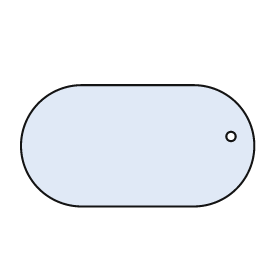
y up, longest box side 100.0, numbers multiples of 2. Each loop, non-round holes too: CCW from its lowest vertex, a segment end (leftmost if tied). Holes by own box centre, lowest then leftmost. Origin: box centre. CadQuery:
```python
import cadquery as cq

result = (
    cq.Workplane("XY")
    .moveTo(-24.0, -26.0)
    .lineTo(24.0, -26.0)
    .threePointArc((50.0, 0.0), (24.0, 26.0))
    .lineTo(-24.0, 26.0)
    .threePointArc((-50.0, 0.0), (-24.0, -26.0))
    .close()
    .moveTo(40.0, 4.0)
    .circle(2.0)
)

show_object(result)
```